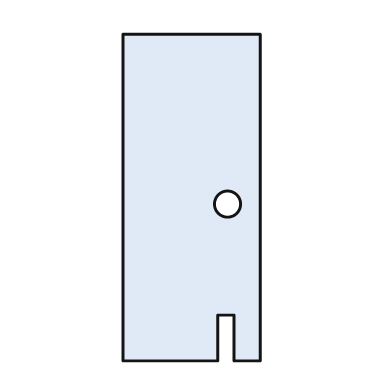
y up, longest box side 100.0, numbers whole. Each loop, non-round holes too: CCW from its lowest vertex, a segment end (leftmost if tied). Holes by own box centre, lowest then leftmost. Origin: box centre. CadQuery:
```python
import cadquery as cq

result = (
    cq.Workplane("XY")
    .moveTo(-21.0, -50.0)
    .lineTo(8.0, -50.0)
    .lineTo(8.0, -36.0)
    .lineTo(13.0, -36.0)
    .lineTo(13.0, -50.0)
    .lineTo(21.0, -50.0)
    .lineTo(21.0, 50.0)
    .lineTo(-21.0, 50.0)
    .close()
    .moveTo(11.0, -2.0)
    .circle(4.0)
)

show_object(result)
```